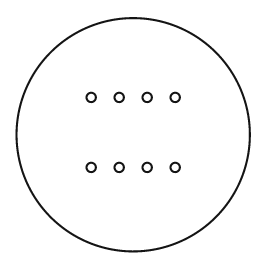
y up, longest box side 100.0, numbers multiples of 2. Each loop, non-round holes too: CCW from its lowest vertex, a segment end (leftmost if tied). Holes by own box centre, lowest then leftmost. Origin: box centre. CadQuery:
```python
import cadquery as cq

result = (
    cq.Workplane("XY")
    .moveTo(0.0, 0.0)
    .circle(50.0)
    .moveTo(-18.0, -14.0)
    .circle(2.0)
    .moveTo(-6.0, -14.0)
    .circle(2.0)
    .moveTo(6.0, -14.0)
    .circle(2.0)
    .moveTo(18.0, -14.0)
    .circle(2.0)
    .moveTo(-18.0, 16.0)
    .circle(2.0)
    .moveTo(-6.0, 16.0)
    .circle(2.0)
    .moveTo(6.0, 16.0)
    .circle(2.0)
    .moveTo(18.0, 16.0)
    .circle(2.0)
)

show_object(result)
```